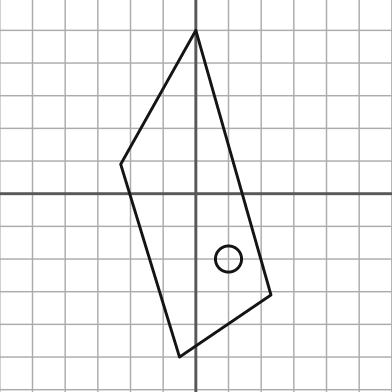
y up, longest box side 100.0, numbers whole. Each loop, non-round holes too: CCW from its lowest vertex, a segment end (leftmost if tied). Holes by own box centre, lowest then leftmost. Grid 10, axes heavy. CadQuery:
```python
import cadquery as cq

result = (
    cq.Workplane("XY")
    .moveTo(-5.0, -50.0)
    .lineTo(23.0, -31.0)
    .lineTo(0.0, 50.0)
    .lineTo(-23.0, 9.0)
    .close()
    .moveTo(10.0, -20.0)
    .circle(4.0)
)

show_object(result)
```